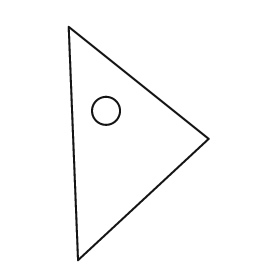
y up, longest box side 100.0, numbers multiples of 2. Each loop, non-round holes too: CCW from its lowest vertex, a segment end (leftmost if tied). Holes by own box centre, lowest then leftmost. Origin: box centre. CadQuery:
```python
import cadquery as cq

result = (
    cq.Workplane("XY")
    .moveTo(-26.0, -50.0)
    .lineTo(30.0, 2.0)
    .lineTo(-30.0, 50.0)
    .close()
    .moveTo(-14.0, 14.0)
    .circle(6.0)
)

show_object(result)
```